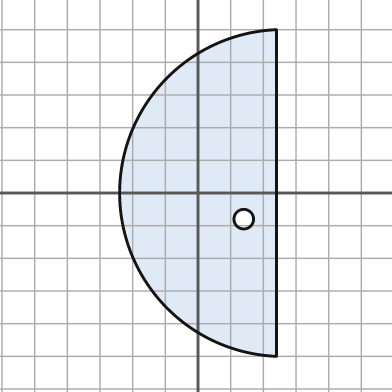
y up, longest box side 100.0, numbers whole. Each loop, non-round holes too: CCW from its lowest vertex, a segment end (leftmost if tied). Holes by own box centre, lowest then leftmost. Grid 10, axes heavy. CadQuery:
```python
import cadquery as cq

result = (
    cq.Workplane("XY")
    .moveTo(24.0, -50.0)
    .lineTo(24.0, 50.0)
    .threePointArc((-24.0, 0.0), (24.0, -50.0))
    .close()
    .moveTo(14.0, -8.0)
    .circle(3.0)
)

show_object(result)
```